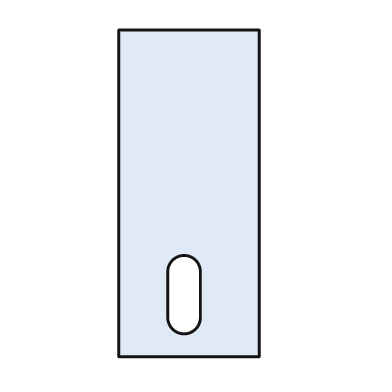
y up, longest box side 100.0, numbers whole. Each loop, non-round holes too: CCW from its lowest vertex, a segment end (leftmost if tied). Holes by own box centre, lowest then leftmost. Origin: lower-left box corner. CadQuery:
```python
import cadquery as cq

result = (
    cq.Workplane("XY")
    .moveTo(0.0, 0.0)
    .lineTo(43.0, 0.0)
    .lineTo(43.0, 100.0)
    .lineTo(0.0, 100.0)
    .close()
    .moveTo(15.0, 12.0)
    .threePointArc((20.0, 7.0), (25.0, 12.0))
    .lineTo(25.0, 26.0)
    .threePointArc((20.0, 31.0), (15.0, 26.0))
    .close()
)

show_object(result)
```